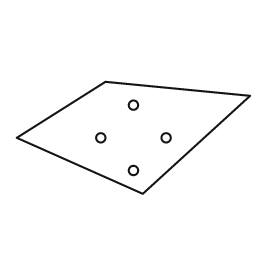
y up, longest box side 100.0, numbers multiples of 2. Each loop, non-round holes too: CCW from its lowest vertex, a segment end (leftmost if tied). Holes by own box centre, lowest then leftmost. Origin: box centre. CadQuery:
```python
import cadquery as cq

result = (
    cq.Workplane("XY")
    .moveTo(4.0, -24.0)
    .lineTo(50.0, 18.0)
    .lineTo(-12.0, 24.0)
    .lineTo(-50.0, 0.0)
    .close()
    .moveTo(0.0, -14.0)
    .circle(2.0)
    .moveTo(-14.0, 0.0)
    .circle(2.0)
    .moveTo(14.0, 0.0)
    .circle(2.0)
    .moveTo(0.0, 14.0)
    .circle(2.0)
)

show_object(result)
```